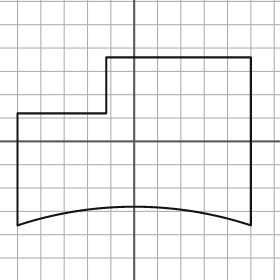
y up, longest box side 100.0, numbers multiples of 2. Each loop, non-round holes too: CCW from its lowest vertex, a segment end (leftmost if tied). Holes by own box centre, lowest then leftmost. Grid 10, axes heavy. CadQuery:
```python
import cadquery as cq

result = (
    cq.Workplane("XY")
    .moveTo(-50.0, -36.0)
    .threePointArc((0.0, -28.0), (50.0, -36.0))
    .lineTo(50.0, 36.0)
    .lineTo(-12.0, 36.0)
    .lineTo(-12.0, 12.0)
    .lineTo(-50.0, 12.0)
    .close()
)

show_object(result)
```